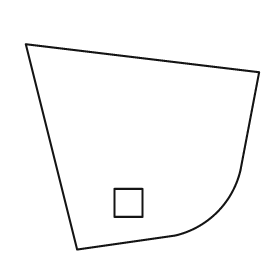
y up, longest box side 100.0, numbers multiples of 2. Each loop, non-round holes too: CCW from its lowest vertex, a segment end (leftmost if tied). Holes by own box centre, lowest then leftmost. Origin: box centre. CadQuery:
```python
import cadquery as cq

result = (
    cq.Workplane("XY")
    .moveTo(-28.0, -44.0)
    .lineTo(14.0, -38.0)
    .threePointArc((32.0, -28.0), (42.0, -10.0))
    .lineTo(50.0, 32.0)
    .lineTo(-50.0, 44.0)
    .close()
    .moveTo(-12.0, -30.0)
    .lineTo(0.0, -30.0)
    .lineTo(0.0, -18.0)
    .lineTo(-12.0, -18.0)
    .close()
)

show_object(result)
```